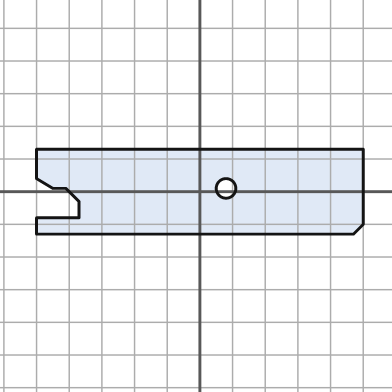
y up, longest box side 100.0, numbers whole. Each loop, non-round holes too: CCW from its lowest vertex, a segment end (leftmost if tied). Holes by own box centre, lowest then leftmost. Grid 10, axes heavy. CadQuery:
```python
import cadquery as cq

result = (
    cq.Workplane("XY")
    .moveTo(-50.0, -13.0)
    .lineTo(47.0, -13.0)
    .lineTo(50.0, -10.0)
    .lineTo(50.0, 13.0)
    .lineTo(-50.0, 13.0)
    .lineTo(-50.0, 4.0)
    .lineTo(-45.0, 1.0)
    .lineTo(-41.0, 1.0)
    .lineTo(-37.0, -3.0)
    .lineTo(-37.0, -8.0)
    .lineTo(-50.0, -8.0)
    .close()
    .moveTo(8.0, 1.0)
    .circle(3.0)
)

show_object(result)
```